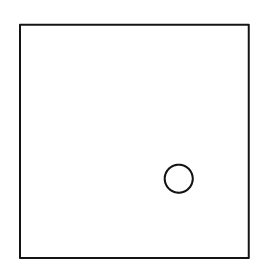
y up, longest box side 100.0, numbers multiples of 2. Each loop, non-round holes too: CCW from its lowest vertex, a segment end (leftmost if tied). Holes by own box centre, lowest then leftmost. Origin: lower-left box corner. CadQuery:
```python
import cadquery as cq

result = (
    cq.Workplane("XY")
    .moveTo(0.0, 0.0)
    .lineTo(98.0, 0.0)
    .lineTo(98.0, 100.0)
    .lineTo(0.0, 100.0)
    .close()
    .moveTo(68.0, 34.0)
    .circle(6.0)
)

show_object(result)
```